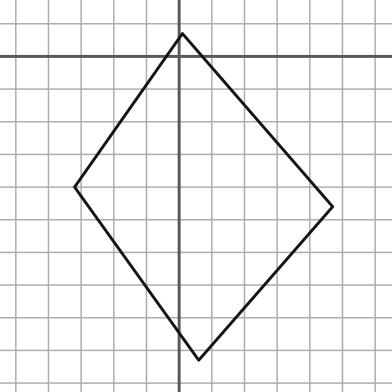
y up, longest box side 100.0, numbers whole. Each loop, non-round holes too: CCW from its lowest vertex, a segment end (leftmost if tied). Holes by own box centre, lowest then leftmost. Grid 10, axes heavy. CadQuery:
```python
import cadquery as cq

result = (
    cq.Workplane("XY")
    .moveTo(6.0, -93.0)
    .lineTo(47.0, -46.0)
    .lineTo(1.0, 7.0)
    .lineTo(-32.0, -40.0)
    .close()
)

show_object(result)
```